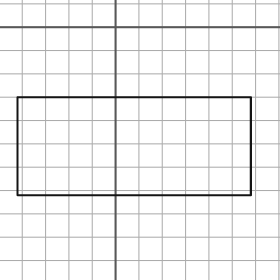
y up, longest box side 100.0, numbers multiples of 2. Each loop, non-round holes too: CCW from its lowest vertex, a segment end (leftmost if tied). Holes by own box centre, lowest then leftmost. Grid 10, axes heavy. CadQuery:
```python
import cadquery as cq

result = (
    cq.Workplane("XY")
    .moveTo(-42.0, -72.0)
    .lineTo(58.0, -72.0)
    .lineTo(58.0, -30.0)
    .lineTo(-42.0, -30.0)
    .close()
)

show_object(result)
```